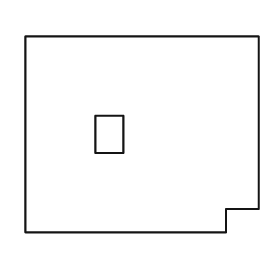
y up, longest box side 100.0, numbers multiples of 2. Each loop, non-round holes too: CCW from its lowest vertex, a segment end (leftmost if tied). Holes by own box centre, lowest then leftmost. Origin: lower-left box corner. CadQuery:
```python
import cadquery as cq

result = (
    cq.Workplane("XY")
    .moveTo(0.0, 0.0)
    .lineTo(86.0, 0.0)
    .lineTo(86.0, 10.0)
    .lineTo(100.0, 10.0)
    .lineTo(100.0, 84.0)
    .lineTo(0.0, 84.0)
    .close()
    .moveTo(30.0, 34.0)
    .lineTo(42.0, 34.0)
    .lineTo(42.0, 50.0)
    .lineTo(30.0, 50.0)
    .close()
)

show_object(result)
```